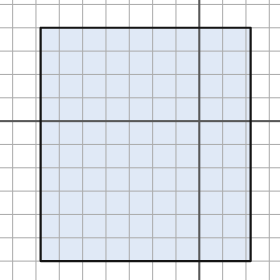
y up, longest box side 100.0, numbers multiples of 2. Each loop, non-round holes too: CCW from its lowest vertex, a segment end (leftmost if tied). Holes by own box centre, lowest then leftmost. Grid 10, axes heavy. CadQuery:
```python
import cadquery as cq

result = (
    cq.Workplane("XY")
    .moveTo(-68.0, -60.0)
    .lineTo(22.0, -60.0)
    .lineTo(22.0, 40.0)
    .lineTo(-68.0, 40.0)
    .close()
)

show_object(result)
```